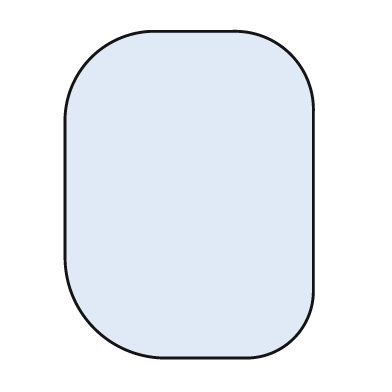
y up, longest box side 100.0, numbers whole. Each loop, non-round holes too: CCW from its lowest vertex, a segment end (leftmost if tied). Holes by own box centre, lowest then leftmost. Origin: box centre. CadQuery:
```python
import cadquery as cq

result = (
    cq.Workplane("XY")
    .moveTo(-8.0, -50.0)
    .lineTo(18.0, -50.0)
    .threePointArc((32.0, -44.0), (38.0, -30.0))
    .lineTo(38.0, 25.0)
    .threePointArc((31.0, 43.0), (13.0, 50.0))
    .lineTo(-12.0, 50.0)
    .threePointArc((-30.0, 42.0), (-38.0, 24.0))
    .lineTo(-38.0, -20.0)
    .threePointArc((-29.0, -41.0), (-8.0, -50.0))
    .close()
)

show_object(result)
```